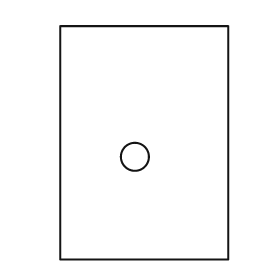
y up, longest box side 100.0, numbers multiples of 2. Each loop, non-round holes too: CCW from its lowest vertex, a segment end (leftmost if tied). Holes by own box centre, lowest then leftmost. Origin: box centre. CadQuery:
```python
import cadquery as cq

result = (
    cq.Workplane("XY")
    .moveTo(-36.0, -50.0)
    .lineTo(36.0, -50.0)
    .lineTo(36.0, 50.0)
    .lineTo(-36.0, 50.0)
    .close()
    .moveTo(-4.0, -6.0)
    .circle(6.0)
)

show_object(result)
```